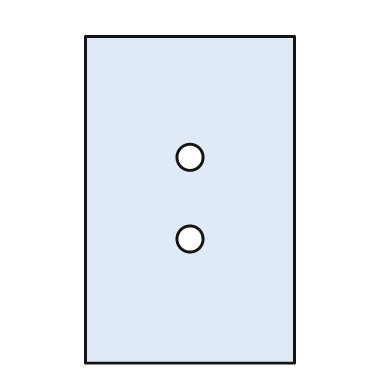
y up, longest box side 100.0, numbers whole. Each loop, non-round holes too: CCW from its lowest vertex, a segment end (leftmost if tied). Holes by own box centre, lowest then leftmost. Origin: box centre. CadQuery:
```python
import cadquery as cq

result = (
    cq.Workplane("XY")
    .moveTo(-32.0, -50.0)
    .lineTo(32.0, -50.0)
    .lineTo(32.0, 50.0)
    .lineTo(-32.0, 50.0)
    .close()
    .moveTo(0.0, -12.0)
    .circle(4.0)
    .moveTo(0.0, 13.0)
    .circle(4.0)
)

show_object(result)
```